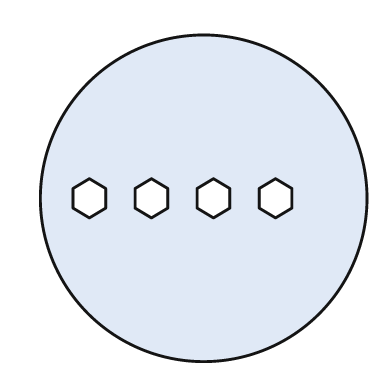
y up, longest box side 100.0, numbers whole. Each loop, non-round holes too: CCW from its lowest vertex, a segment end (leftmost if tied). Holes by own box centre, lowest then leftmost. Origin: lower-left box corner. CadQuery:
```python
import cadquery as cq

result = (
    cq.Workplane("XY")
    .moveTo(50.0, 50.0)
    .circle(50.0)
    .moveTo(15.0, 44.0)
    .lineTo(20.0, 47.0)
    .lineTo(20.0, 53.0)
    .lineTo(15.0, 56.0)
    .lineTo(10.0, 53.0)
    .lineTo(10.0, 47.0)
    .close()
    .moveTo(34.0, 44.0)
    .lineTo(39.0, 47.0)
    .lineTo(39.0, 53.0)
    .lineTo(34.0, 56.0)
    .lineTo(29.0, 53.0)
    .lineTo(29.0, 47.0)
    .close()
    .moveTo(53.0, 44.0)
    .lineTo(58.0, 47.0)
    .lineTo(58.0, 53.0)
    .lineTo(53.0, 56.0)
    .lineTo(48.0, 53.0)
    .lineTo(48.0, 47.0)
    .close()
    .moveTo(72.0, 44.0)
    .lineTo(77.0, 47.0)
    .lineTo(77.0, 53.0)
    .lineTo(72.0, 56.0)
    .lineTo(67.0, 53.0)
    .lineTo(67.0, 47.0)
    .close()
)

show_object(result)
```